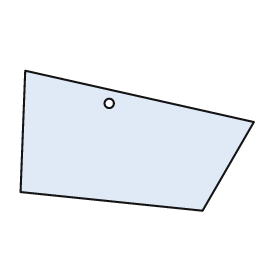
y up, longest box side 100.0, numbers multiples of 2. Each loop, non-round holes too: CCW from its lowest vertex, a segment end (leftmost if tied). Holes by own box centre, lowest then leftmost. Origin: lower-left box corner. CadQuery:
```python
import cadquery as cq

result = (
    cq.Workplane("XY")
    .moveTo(78.0, 0.0)
    .lineTo(100.0, 38.0)
    .lineTo(2.0, 60.0)
    .lineTo(0.0, 8.0)
    .close()
    .moveTo(38.0, 46.0)
    .circle(2.0)
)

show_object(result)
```